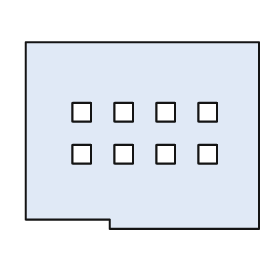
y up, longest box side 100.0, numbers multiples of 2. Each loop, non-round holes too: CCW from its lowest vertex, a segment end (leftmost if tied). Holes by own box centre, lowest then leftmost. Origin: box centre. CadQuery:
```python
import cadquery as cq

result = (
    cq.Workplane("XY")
    .moveTo(-14.0, -40.0)
    .lineTo(50.0, -40.0)
    .lineTo(50.0, 40.0)
    .lineTo(-50.0, 40.0)
    .lineTo(-50.0, -36.0)
    .lineTo(-14.0, -36.0)
    .close()
    .moveTo(-30.0, -12.0)
    .lineTo(-22.0, -12.0)
    .lineTo(-22.0, -4.0)
    .lineTo(-30.0, -4.0)
    .close()
    .moveTo(-12.0, -12.0)
    .lineTo(-4.0, -12.0)
    .lineTo(-4.0, -4.0)
    .lineTo(-12.0, -4.0)
    .close()
    .moveTo(6.0, -12.0)
    .lineTo(14.0, -12.0)
    .lineTo(14.0, -4.0)
    .lineTo(6.0, -4.0)
    .close()
    .moveTo(24.0, -12.0)
    .lineTo(32.0, -12.0)
    .lineTo(32.0, -4.0)
    .lineTo(24.0, -4.0)
    .close()
    .moveTo(-30.0, 6.0)
    .lineTo(-22.0, 6.0)
    .lineTo(-22.0, 14.0)
    .lineTo(-30.0, 14.0)
    .close()
    .moveTo(-12.0, 6.0)
    .lineTo(-4.0, 6.0)
    .lineTo(-4.0, 14.0)
    .lineTo(-12.0, 14.0)
    .close()
    .moveTo(6.0, 6.0)
    .lineTo(14.0, 6.0)
    .lineTo(14.0, 14.0)
    .lineTo(6.0, 14.0)
    .close()
    .moveTo(24.0, 6.0)
    .lineTo(32.0, 6.0)
    .lineTo(32.0, 14.0)
    .lineTo(24.0, 14.0)
    .close()
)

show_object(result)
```